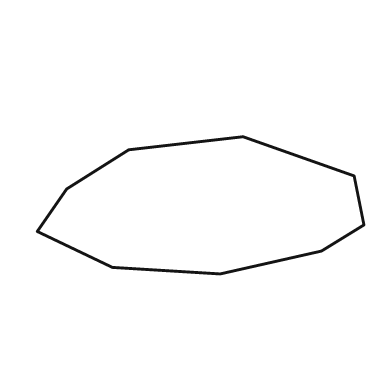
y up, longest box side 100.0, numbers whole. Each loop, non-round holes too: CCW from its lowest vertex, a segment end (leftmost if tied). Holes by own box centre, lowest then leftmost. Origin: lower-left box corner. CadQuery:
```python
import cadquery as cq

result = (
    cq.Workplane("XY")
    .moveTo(56.0, 0.0)
    .lineTo(87.0, 7.0)
    .lineTo(100.0, 15.0)
    .lineTo(97.0, 30.0)
    .lineTo(63.0, 42.0)
    .lineTo(28.0, 38.0)
    .lineTo(9.0, 26.0)
    .lineTo(0.0, 13.0)
    .lineTo(23.0, 2.0)
    .close()
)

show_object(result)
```